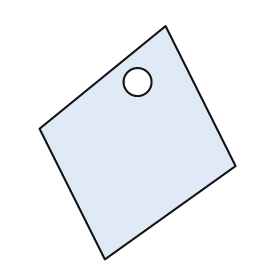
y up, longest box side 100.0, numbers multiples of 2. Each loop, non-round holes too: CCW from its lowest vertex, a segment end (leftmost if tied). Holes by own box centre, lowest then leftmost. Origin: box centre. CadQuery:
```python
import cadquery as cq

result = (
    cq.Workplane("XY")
    .moveTo(-14.0, -50.0)
    .lineTo(42.0, -10.0)
    .lineTo(12.0, 50.0)
    .lineTo(-42.0, 6.0)
    .close()
    .moveTo(0.0, 26.0)
    .circle(6.0)
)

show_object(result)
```